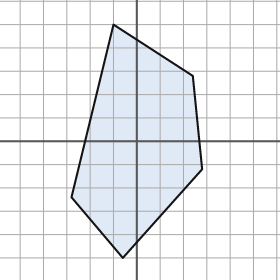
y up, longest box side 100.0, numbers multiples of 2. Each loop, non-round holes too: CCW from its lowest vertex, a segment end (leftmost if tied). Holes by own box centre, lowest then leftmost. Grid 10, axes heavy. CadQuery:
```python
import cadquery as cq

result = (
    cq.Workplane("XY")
    .moveTo(-6.0, -50.0)
    .lineTo(28.0, -12.0)
    .lineTo(24.0, 28.0)
    .lineTo(-10.0, 50.0)
    .lineTo(-28.0, -24.0)
    .close()
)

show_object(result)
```